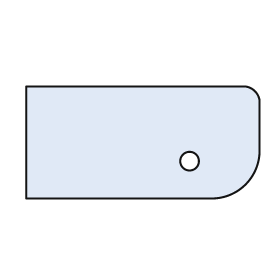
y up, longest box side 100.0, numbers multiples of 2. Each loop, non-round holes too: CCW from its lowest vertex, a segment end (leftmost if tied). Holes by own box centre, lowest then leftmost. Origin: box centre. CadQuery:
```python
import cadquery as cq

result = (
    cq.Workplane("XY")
    .moveTo(-50.0, -24.0)
    .lineTo(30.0, -24.0)
    .threePointArc((44.0, -18.0), (50.0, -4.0))
    .lineTo(50.0, 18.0)
    .threePointArc((48.0, 22.0), (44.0, 24.0))
    .lineTo(-50.0, 24.0)
    .close()
    .moveTo(20.0, -8.0)
    .circle(4.0)
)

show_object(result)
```